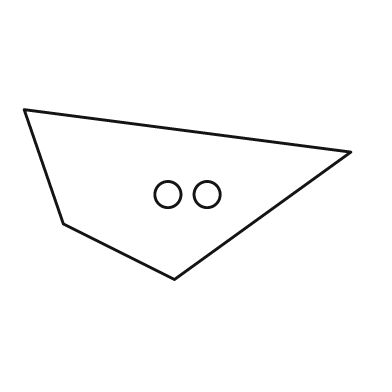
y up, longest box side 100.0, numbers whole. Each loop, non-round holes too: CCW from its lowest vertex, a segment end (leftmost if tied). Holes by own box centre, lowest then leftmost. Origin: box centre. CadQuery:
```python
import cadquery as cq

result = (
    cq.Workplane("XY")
    .moveTo(-4.0, -26.0)
    .lineTo(50.0, 13.0)
    .lineTo(-50.0, 26.0)
    .lineTo(-38.0, -9.0)
    .close()
    .moveTo(-6.0, 0.0)
    .circle(4.0)
    .moveTo(6.0, 0.0)
    .circle(4.0)
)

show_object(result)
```